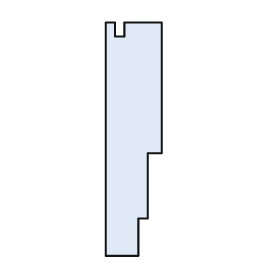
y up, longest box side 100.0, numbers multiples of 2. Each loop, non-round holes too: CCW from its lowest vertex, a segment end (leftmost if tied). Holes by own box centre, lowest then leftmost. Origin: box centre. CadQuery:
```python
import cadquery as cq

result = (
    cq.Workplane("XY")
    .moveTo(-12.0, -50.0)
    .lineTo(2.0, -50.0)
    .lineTo(2.0, -34.0)
    .lineTo(6.0, -34.0)
    .lineTo(6.0, -6.0)
    .lineTo(12.0, -6.0)
    .lineTo(12.0, 50.0)
    .lineTo(-4.0, 50.0)
    .lineTo(-4.0, 44.0)
    .lineTo(-8.0, 44.0)
    .lineTo(-8.0, 50.0)
    .lineTo(-12.0, 50.0)
    .close()
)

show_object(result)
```